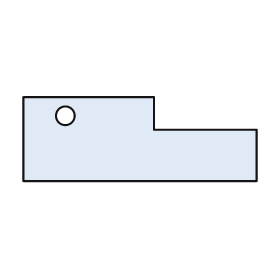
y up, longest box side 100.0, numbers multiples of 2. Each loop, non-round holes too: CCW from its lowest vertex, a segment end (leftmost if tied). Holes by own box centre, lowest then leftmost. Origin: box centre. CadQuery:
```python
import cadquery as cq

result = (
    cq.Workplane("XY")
    .moveTo(-50.0, -18.0)
    .lineTo(50.0, -18.0)
    .lineTo(50.0, 4.0)
    .lineTo(6.0, 4.0)
    .lineTo(6.0, 18.0)
    .lineTo(-50.0, 18.0)
    .close()
    .moveTo(-32.0, 10.0)
    .circle(4.0)
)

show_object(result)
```